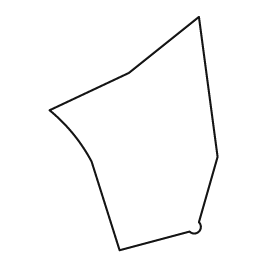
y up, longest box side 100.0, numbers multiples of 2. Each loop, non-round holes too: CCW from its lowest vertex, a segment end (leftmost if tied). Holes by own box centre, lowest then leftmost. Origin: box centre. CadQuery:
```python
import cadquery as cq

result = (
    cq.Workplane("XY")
    .moveTo(-6.0, -50.0)
    .lineTo(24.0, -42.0)
    .threePointArc((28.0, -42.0), (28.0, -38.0))
    .lineTo(36.0, -10.0)
    .lineTo(28.0, 50.0)
    .lineTo(-2.0, 26.0)
    .lineTo(-36.0, 10.0)
    .threePointArc((-26.0, 0.0), (-18.0, -12.0))
    .close()
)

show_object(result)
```